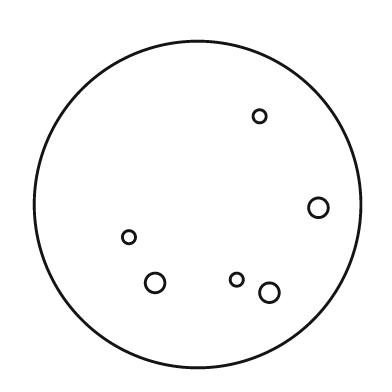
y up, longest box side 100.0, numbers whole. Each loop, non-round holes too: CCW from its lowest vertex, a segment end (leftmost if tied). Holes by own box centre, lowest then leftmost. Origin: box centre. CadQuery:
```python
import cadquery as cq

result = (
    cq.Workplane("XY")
    .moveTo(0.0, 0.0)
    .circle(50.0)
    .moveTo(22.0, -27.0)
    .circle(3.0)
    .moveTo(-13.0, -24.0)
    .circle(3.0)
    .moveTo(12.0, -23.0)
    .circle(2.0)
    .moveTo(-21.0, -10.0)
    .circle(2.0)
    .moveTo(37.0, -1.0)
    .circle(3.0)
    .moveTo(19.0, 27.0)
    .circle(2.0)
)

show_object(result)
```